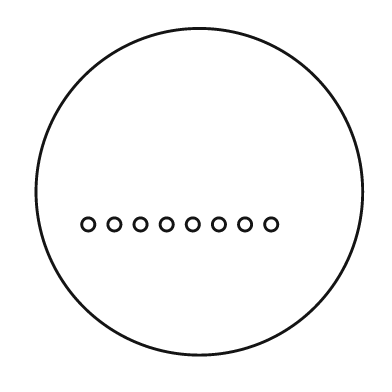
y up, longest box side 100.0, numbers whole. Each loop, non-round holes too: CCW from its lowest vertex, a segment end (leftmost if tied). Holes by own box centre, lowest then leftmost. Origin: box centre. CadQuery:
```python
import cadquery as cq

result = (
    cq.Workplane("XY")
    .moveTo(0.0, 0.0)
    .circle(50.0)
    .moveTo(-34.0, -10.0)
    .circle(2.0)
    .moveTo(-26.0, -10.0)
    .circle(2.0)
    .moveTo(-18.0, -10.0)
    .circle(2.0)
    .moveTo(-10.0, -10.0)
    .circle(2.0)
    .moveTo(-2.0, -10.0)
    .circle(2.0)
    .moveTo(6.0, -10.0)
    .circle(2.0)
    .moveTo(14.0, -10.0)
    .circle(2.0)
    .moveTo(22.0, -10.0)
    .circle(2.0)
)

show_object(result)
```